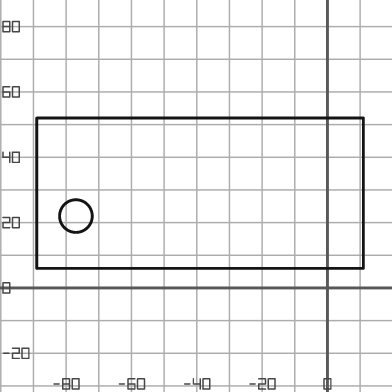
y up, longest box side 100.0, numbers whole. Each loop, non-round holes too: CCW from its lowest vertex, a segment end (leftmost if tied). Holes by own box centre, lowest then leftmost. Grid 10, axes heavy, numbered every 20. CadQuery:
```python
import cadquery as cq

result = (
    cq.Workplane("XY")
    .moveTo(-89.0, 6.0)
    .lineTo(11.0, 6.0)
    .lineTo(11.0, 52.0)
    .lineTo(-89.0, 52.0)
    .close()
    .moveTo(-77.0, 22.0)
    .circle(5.0)
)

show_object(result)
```